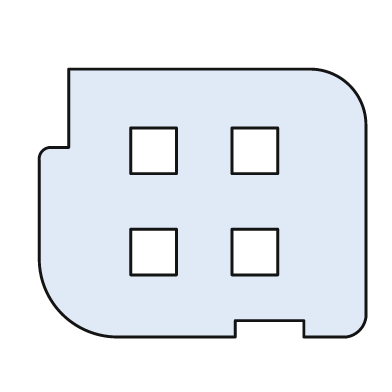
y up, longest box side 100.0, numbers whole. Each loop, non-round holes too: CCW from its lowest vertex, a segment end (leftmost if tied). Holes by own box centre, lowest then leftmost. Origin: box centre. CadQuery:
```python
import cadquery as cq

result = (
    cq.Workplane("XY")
    .moveTo(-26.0, -41.0)
    .lineTo(10.0, -41.0)
    .lineTo(10.0, -36.0)
    .lineTo(31.0, -36.0)
    .lineTo(31.0, -41.0)
    .lineTo(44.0, -41.0)
    .threePointArc((48.0, -39.0), (50.0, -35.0))
    .lineTo(50.0, 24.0)
    .threePointArc((45.0, 36.0), (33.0, 41.0))
    .lineTo(-41.0, 41.0)
    .lineTo(-41.0, 17.0)
    .lineTo(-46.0, 17.0)
    .threePointArc((-49.0, 16.0), (-50.0, 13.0))
    .lineTo(-50.0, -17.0)
    .threePointArc((-43.0, -34.0), (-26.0, -41.0))
    .close()
    .moveTo(-22.0, -22.0)
    .lineTo(-8.0, -22.0)
    .lineTo(-8.0, -8.0)
    .lineTo(-22.0, -8.0)
    .close()
    .moveTo(9.0, -22.0)
    .lineTo(23.0, -22.0)
    .lineTo(23.0, -8.0)
    .lineTo(9.0, -8.0)
    .close()
    .moveTo(-22.0, 9.0)
    .lineTo(-8.0, 9.0)
    .lineTo(-8.0, 23.0)
    .lineTo(-22.0, 23.0)
    .close()
    .moveTo(9.0, 9.0)
    .lineTo(23.0, 9.0)
    .lineTo(23.0, 23.0)
    .lineTo(9.0, 23.0)
    .close()
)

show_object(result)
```